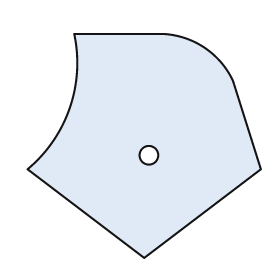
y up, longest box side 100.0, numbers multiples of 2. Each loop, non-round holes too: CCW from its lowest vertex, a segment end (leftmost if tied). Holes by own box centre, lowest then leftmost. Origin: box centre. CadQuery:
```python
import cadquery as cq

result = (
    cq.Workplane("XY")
    .moveTo(0.0, -48.0)
    .lineTo(50.0, -10.0)
    .lineTo(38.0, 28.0)
    .threePointArc((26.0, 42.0), (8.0, 48.0))
    .lineTo(-30.0, 48.0)
    .threePointArc((-32.0, 16.0), (-50.0, -10.0))
    .close()
    .moveTo(2.0, -4.0)
    .circle(4.0)
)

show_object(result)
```